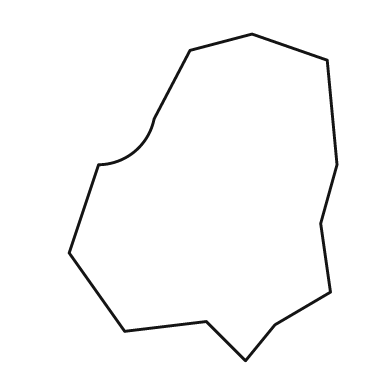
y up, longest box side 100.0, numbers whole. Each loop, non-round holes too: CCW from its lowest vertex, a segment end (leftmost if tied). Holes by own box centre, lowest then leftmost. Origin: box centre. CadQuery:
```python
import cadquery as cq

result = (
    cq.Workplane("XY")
    .moveTo(13.0, -50.0)
    .lineTo(22.0, -39.0)
    .lineTo(39.0, -29.0)
    .lineTo(36.0, -8.0)
    .lineTo(41.0, 10.0)
    .lineTo(38.0, 42.0)
    .lineTo(15.0, 50.0)
    .lineTo(-4.0, 45.0)
    .lineTo(-15.0, 24.0)
    .threePointArc((-21.0, 14.0), (-32.0, 10.0))
    .lineTo(-41.0, -17.0)
    .lineTo(-24.0, -41.0)
    .lineTo(1.0, -38.0)
    .close()
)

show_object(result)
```